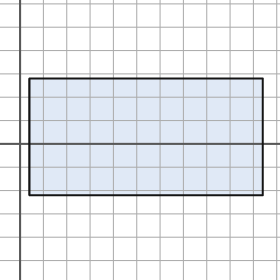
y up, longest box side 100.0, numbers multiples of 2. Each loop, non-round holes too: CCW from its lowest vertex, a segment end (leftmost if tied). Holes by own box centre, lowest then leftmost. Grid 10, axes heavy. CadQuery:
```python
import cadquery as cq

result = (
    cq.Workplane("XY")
    .moveTo(4.0, -22.0)
    .lineTo(104.0, -22.0)
    .lineTo(104.0, 28.0)
    .lineTo(4.0, 28.0)
    .close()
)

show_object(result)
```